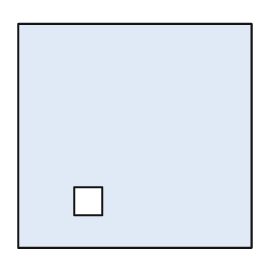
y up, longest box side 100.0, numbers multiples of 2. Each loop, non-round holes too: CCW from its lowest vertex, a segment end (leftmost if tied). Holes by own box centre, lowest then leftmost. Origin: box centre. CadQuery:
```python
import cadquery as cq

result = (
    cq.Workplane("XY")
    .moveTo(-50.0, -48.0)
    .lineTo(50.0, -48.0)
    .lineTo(50.0, 48.0)
    .lineTo(-50.0, 48.0)
    .close()
    .moveTo(-26.0, -34.0)
    .lineTo(-14.0, -34.0)
    .lineTo(-14.0, -22.0)
    .lineTo(-26.0, -22.0)
    .close()
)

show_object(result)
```